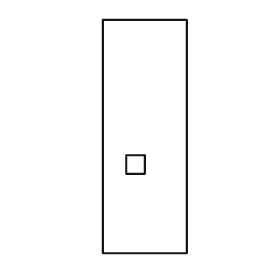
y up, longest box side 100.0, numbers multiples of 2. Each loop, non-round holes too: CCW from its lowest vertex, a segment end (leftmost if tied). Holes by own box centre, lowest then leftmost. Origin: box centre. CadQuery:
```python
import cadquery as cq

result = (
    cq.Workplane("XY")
    .moveTo(-18.0, -50.0)
    .lineTo(18.0, -50.0)
    .lineTo(18.0, 50.0)
    .lineTo(-18.0, 50.0)
    .close()
    .moveTo(-8.0, -16.0)
    .lineTo(0.0, -16.0)
    .lineTo(0.0, -8.0)
    .lineTo(-8.0, -8.0)
    .close()
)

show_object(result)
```